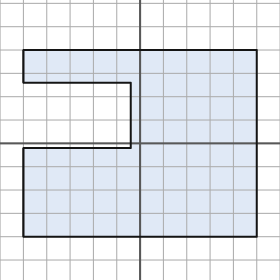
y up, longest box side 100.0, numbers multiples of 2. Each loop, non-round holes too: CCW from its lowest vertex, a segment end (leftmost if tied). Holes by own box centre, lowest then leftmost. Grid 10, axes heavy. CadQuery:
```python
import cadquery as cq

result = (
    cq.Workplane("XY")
    .moveTo(-50.0, -40.0)
    .lineTo(50.0, -40.0)
    .lineTo(50.0, 40.0)
    .lineTo(-50.0, 40.0)
    .lineTo(-50.0, 26.0)
    .lineTo(-4.0, 26.0)
    .lineTo(-4.0, -2.0)
    .lineTo(-50.0, -2.0)
    .close()
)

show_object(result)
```